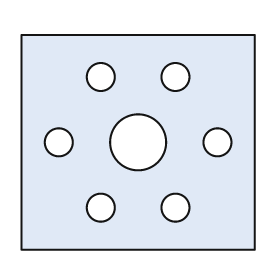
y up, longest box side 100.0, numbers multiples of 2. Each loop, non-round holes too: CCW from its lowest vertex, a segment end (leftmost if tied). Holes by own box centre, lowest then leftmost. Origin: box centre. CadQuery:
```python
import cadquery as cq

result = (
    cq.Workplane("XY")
    .moveTo(-50.0, -46.0)
    .lineTo(50.0, -46.0)
    .lineTo(50.0, 46.0)
    .lineTo(-50.0, 46.0)
    .close()
    .moveTo(-16.0, -28.0)
    .circle(6.0)
    .moveTo(16.0, -28.0)
    .circle(6.0)
    .moveTo(-34.0, 0.0)
    .circle(6.0)
    .moveTo(0.0, 0.0)
    .circle(12.0)
    .moveTo(34.0, 0.0)
    .circle(6.0)
    .moveTo(-16.0, 28.0)
    .circle(6.0)
    .moveTo(16.0, 28.0)
    .circle(6.0)
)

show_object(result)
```